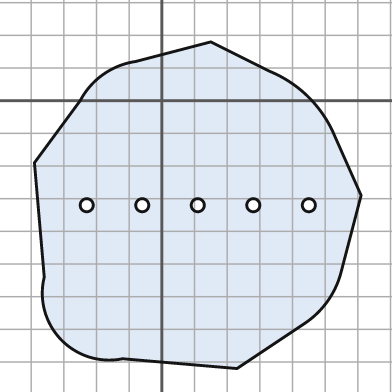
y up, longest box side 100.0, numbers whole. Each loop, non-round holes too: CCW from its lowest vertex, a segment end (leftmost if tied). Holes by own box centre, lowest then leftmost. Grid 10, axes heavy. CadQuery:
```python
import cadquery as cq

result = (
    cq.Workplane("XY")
    .moveTo(23.0, -82.0)
    .lineTo(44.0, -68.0)
    .threePointArc((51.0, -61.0), (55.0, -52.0))
    .lineTo(61.0, -29.0)
    .lineTo(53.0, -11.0)
    .threePointArc((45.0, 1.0), (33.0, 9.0))
    .lineTo(15.0, 18.0)
    .lineTo(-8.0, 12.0)
    .threePointArc((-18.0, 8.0), (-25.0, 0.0))
    .lineTo(-39.0, -19.0)
    .lineTo(-36.0, -54.0)
    .threePointArc((-31.0, -73.0), (-12.0, -79.0))
    .close()
    .moveTo(-23.0, -32.0)
    .circle(2.0)
    .moveTo(-6.0, -32.0)
    .circle(2.0)
    .moveTo(11.0, -32.0)
    .circle(2.0)
    .moveTo(28.0, -32.0)
    .circle(2.0)
    .moveTo(45.0, -32.0)
    .circle(2.0)
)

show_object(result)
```